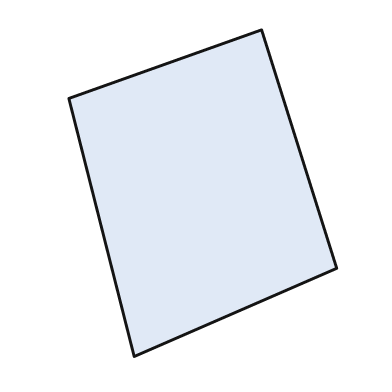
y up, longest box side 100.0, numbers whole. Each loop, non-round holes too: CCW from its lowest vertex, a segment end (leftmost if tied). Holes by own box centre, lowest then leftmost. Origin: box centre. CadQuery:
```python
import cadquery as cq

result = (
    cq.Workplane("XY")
    .moveTo(-21.0, -50.0)
    .lineTo(41.0, -23.0)
    .lineTo(18.0, 50.0)
    .lineTo(-41.0, 29.0)
    .close()
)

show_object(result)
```